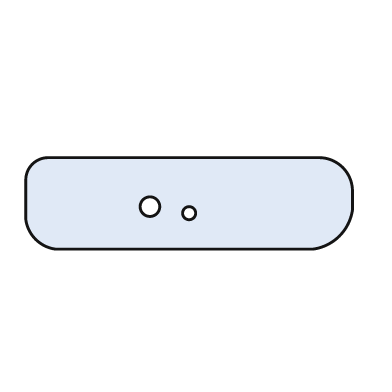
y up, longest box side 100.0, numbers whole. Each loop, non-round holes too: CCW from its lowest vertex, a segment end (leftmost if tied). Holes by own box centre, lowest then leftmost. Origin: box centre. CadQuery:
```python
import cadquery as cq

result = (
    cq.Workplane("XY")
    .moveTo(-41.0, -14.0)
    .lineTo(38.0, -14.0)
    .threePointArc((46.0, -10.0), (50.0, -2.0))
    .lineTo(50.0, 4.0)
    .threePointArc((47.0, 11.0), (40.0, 14.0))
    .lineTo(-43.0, 14.0)
    .threePointArc((-48.0, 12.0), (-50.0, 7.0))
    .lineTo(-50.0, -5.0)
    .threePointArc((-47.0, -11.0), (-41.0, -14.0))
    .close()
    .moveTo(0.0, -3.0)
    .circle(2.0)
    .moveTo(-12.0, -1.0)
    .circle(3.0)
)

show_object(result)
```